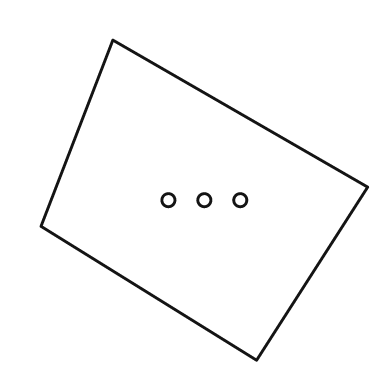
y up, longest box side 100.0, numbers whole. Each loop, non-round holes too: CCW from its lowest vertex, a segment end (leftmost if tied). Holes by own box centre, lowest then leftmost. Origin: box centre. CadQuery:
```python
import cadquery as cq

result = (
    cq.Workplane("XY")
    .moveTo(16.0, -49.0)
    .lineTo(50.0, 4.0)
    .lineTo(-28.0, 49.0)
    .lineTo(-50.0, -8.0)
    .close()
    .moveTo(-11.0, 0.0)
    .circle(2.0)
    .moveTo(0.0, 0.0)
    .circle(2.0)
    .moveTo(11.0, 0.0)
    .circle(2.0)
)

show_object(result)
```